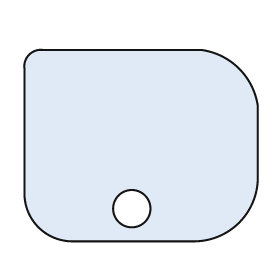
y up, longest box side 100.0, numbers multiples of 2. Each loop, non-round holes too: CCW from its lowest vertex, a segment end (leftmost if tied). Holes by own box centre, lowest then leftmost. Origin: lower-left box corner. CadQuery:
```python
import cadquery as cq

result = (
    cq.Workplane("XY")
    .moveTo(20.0, 0.0)
    .lineTo(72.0, 0.0)
    .threePointArc((92.0, 8.0), (100.0, 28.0))
    .lineTo(100.0, 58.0)
    .threePointArc((92.0, 74.0), (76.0, 82.0))
    .lineTo(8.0, 82.0)
    .threePointArc((2.0, 80.0), (0.0, 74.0))
    .lineTo(0.0, 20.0)
    .threePointArc((6.0, 6.0), (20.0, 0.0))
    .close()
    .moveTo(46.0, 14.0)
    .circle(8.0)
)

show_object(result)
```